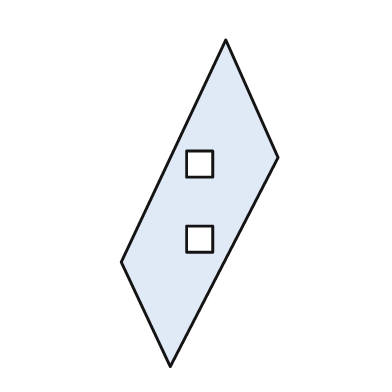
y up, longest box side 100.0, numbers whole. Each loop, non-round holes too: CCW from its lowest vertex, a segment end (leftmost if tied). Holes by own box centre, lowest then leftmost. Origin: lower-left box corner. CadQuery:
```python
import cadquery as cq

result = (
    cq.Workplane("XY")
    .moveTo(15.0, 0.0)
    .lineTo(48.0, 64.0)
    .lineTo(32.0, 100.0)
    .lineTo(0.0, 32.0)
    .close()
    .moveTo(20.0, 35.0)
    .lineTo(28.0, 35.0)
    .lineTo(28.0, 43.0)
    .lineTo(20.0, 43.0)
    .close()
    .moveTo(20.0, 58.0)
    .lineTo(28.0, 58.0)
    .lineTo(28.0, 66.0)
    .lineTo(20.0, 66.0)
    .close()
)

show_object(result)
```